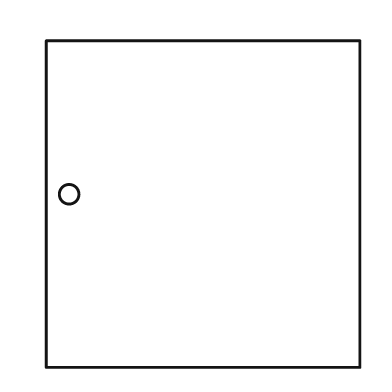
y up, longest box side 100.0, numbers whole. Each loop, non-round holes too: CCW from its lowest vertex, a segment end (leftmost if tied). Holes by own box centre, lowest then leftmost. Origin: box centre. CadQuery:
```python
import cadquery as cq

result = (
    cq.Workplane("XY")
    .moveTo(-48.0, -50.0)
    .lineTo(48.0, -50.0)
    .lineTo(48.0, 50.0)
    .lineTo(-48.0, 50.0)
    .close()
    .moveTo(-41.0, 3.0)
    .circle(3.0)
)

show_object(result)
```